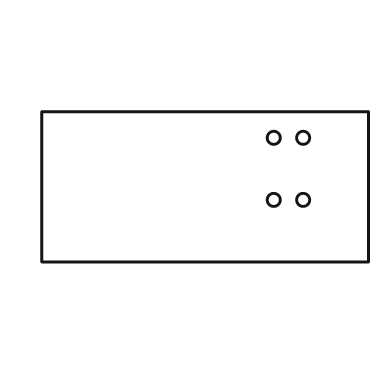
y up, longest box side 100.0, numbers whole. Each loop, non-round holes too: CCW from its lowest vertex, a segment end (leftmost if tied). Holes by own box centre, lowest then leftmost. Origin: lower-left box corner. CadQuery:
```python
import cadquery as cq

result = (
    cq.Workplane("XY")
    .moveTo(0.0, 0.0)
    .lineTo(100.0, 0.0)
    .lineTo(100.0, 46.0)
    .lineTo(0.0, 46.0)
    .close()
    .moveTo(71.0, 19.0)
    .circle(2.0)
    .moveTo(80.0, 19.0)
    .circle(2.0)
    .moveTo(71.0, 38.0)
    .circle(2.0)
    .moveTo(80.0, 38.0)
    .circle(2.0)
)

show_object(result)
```